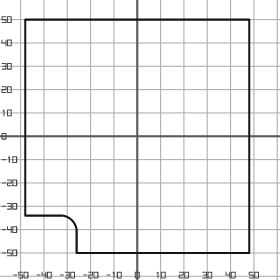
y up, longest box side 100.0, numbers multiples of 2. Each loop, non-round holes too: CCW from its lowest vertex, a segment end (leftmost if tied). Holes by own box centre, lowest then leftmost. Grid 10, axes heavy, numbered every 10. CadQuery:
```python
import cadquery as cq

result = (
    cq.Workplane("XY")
    .moveTo(-26.0, -50.0)
    .lineTo(48.0, -50.0)
    .lineTo(48.0, 50.0)
    .lineTo(-48.0, 50.0)
    .lineTo(-48.0, -34.0)
    .lineTo(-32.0, -34.0)
    .threePointArc((-28.0, -36.0), (-26.0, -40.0))
    .close()
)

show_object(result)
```